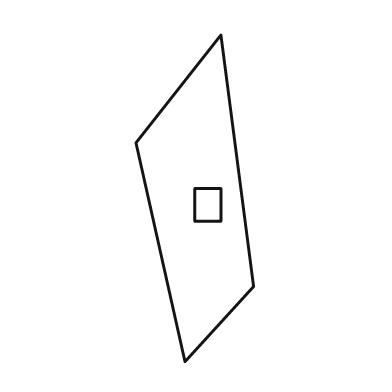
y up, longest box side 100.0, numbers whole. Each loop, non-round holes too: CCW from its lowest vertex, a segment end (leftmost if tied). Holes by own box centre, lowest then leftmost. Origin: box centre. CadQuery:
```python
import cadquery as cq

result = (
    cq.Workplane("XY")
    .moveTo(-3.0, -50.0)
    .lineTo(18.0, -27.0)
    .lineTo(8.0, 50.0)
    .lineTo(-18.0, 17.0)
    .close()
    .moveTo(0.0, -7.0)
    .lineTo(8.0, -7.0)
    .lineTo(8.0, 3.0)
    .lineTo(0.0, 3.0)
    .close()
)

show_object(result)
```